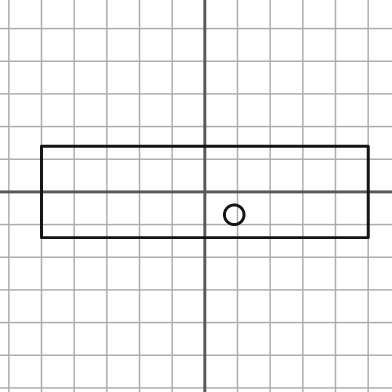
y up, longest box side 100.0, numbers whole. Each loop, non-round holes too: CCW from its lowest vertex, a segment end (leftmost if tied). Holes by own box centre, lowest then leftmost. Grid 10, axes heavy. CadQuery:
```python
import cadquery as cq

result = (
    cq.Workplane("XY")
    .moveTo(-50.0, -14.0)
    .lineTo(50.0, -14.0)
    .lineTo(50.0, 14.0)
    .lineTo(-50.0, 14.0)
    .close()
    .moveTo(9.0, -7.0)
    .circle(3.0)
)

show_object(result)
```